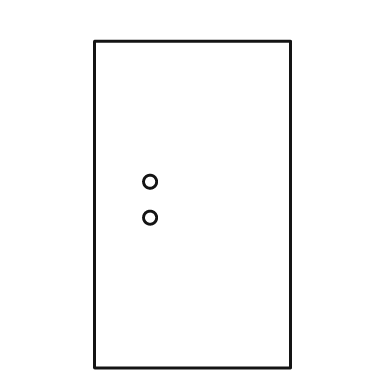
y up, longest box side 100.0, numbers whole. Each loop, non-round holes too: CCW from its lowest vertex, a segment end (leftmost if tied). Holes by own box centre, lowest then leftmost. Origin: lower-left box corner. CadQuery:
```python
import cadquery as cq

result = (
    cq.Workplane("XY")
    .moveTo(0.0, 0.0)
    .lineTo(60.0, 0.0)
    .lineTo(60.0, 100.0)
    .lineTo(0.0, 100.0)
    .close()
    .moveTo(17.0, 46.0)
    .circle(2.0)
    .moveTo(17.0, 57.0)
    .circle(2.0)
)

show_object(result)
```